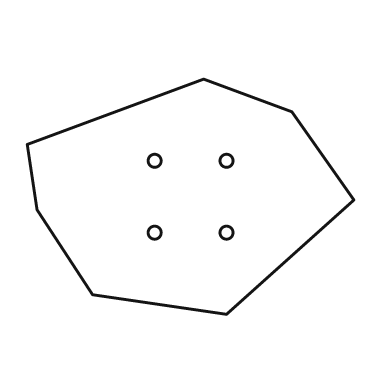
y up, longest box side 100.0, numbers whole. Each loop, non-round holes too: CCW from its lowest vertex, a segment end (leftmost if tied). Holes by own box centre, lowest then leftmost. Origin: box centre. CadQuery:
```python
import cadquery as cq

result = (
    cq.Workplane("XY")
    .moveTo(11.0, -36.0)
    .lineTo(50.0, -1.0)
    .lineTo(31.0, 26.0)
    .lineTo(4.0, 36.0)
    .lineTo(-50.0, 16.0)
    .lineTo(-47.0, -4.0)
    .lineTo(-30.0, -30.0)
    .close()
    .moveTo(-11.0, -11.0)
    .circle(2.0)
    .moveTo(11.0, -11.0)
    .circle(2.0)
    .moveTo(-11.0, 11.0)
    .circle(2.0)
    .moveTo(11.0, 11.0)
    .circle(2.0)
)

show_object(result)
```